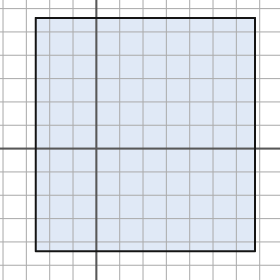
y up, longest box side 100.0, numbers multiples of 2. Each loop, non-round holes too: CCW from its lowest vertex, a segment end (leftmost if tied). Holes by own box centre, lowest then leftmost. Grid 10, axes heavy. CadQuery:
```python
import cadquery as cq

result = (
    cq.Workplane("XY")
    .moveTo(-26.0, -44.0)
    .lineTo(68.0, -44.0)
    .lineTo(68.0, 56.0)
    .lineTo(-26.0, 56.0)
    .close()
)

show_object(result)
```